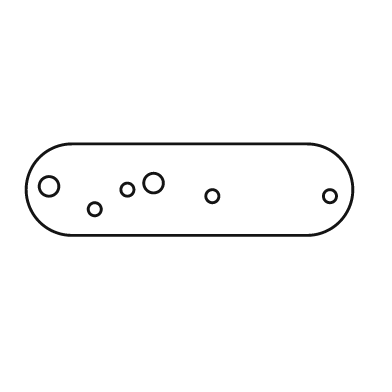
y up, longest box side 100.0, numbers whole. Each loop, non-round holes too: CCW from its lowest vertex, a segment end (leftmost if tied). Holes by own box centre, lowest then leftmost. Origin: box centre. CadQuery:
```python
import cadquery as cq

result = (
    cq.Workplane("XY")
    .moveTo(-36.0, -14.0)
    .lineTo(36.0, -14.0)
    .threePointArc((50.0, 0.0), (36.0, 14.0))
    .lineTo(-36.0, 14.0)
    .threePointArc((-50.0, 0.0), (-36.0, -14.0))
    .close()
    .moveTo(-29.0, -6.0)
    .circle(2.0)
    .moveTo(7.0, -2.0)
    .circle(2.0)
    .moveTo(43.0, -2.0)
    .circle(2.0)
    .moveTo(-19.0, 0.0)
    .circle(2.0)
    .moveTo(-43.0, 1.0)
    .circle(3.0)
    .moveTo(-11.0, 2.0)
    .circle(3.0)
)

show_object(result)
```